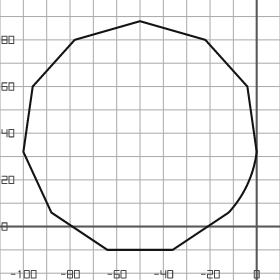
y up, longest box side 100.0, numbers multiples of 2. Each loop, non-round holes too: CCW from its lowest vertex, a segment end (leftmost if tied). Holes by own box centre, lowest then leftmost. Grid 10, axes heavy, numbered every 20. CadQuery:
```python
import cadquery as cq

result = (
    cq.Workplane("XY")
    .moveTo(-64.0, -10.0)
    .lineTo(-36.0, -10.0)
    .lineTo(-12.0, 6.0)
    .threePointArc((-4.0, 18.0), (0.0, 32.0))
    .lineTo(-4.0, 60.0)
    .lineTo(-22.0, 80.0)
    .lineTo(-50.0, 88.0)
    .lineTo(-78.0, 80.0)
    .lineTo(-96.0, 60.0)
    .lineTo(-100.0, 32.0)
    .lineTo(-88.0, 6.0)
    .close()
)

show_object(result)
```